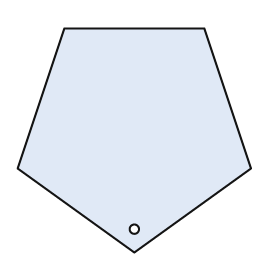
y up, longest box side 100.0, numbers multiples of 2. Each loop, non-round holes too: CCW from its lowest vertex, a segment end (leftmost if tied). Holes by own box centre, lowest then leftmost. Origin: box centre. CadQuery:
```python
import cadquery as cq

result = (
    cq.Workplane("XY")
    .moveTo(0.0, -48.0)
    .lineTo(50.0, -12.0)
    .lineTo(30.0, 48.0)
    .lineTo(-30.0, 48.0)
    .lineTo(-50.0, -12.0)
    .close()
    .moveTo(0.0, -38.0)
    .circle(2.0)
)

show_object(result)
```